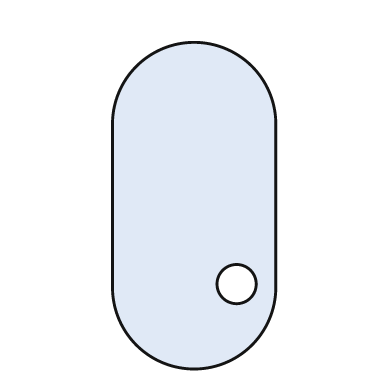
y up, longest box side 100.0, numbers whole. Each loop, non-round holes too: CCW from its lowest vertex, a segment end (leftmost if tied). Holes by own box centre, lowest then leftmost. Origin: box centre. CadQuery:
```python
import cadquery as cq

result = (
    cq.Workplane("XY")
    .moveTo(-25.0, -25.0)
    .threePointArc((0.0, -50.0), (25.0, -25.0))
    .lineTo(25.0, 25.0)
    .threePointArc((0.0, 50.0), (-25.0, 25.0))
    .close()
    .moveTo(13.0, -24.0)
    .circle(6.0)
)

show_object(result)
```